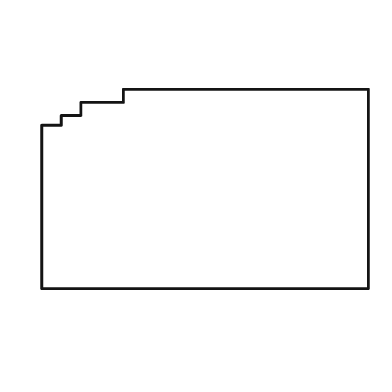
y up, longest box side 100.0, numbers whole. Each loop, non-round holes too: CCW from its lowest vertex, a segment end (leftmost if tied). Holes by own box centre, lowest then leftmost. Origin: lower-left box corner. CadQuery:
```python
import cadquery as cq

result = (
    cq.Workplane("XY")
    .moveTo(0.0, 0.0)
    .lineTo(100.0, 0.0)
    .lineTo(100.0, 61.0)
    .lineTo(25.0, 61.0)
    .lineTo(25.0, 57.0)
    .lineTo(12.0, 57.0)
    .lineTo(12.0, 53.0)
    .lineTo(6.0, 53.0)
    .lineTo(6.0, 50.0)
    .lineTo(0.0, 50.0)
    .close()
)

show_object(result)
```